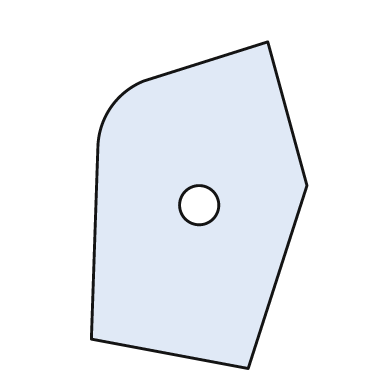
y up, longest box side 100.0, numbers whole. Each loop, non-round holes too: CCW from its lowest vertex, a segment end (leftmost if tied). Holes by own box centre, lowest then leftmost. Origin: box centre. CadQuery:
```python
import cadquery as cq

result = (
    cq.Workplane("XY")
    .moveTo(15.0, -50.0)
    .lineTo(33.0, 6.0)
    .lineTo(21.0, 50.0)
    .lineTo(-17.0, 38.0)
    .threePointArc((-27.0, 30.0), (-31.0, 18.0))
    .lineTo(-33.0, -41.0)
    .close()
    .moveTo(0.0, 0.0)
    .circle(6.0)
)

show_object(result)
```